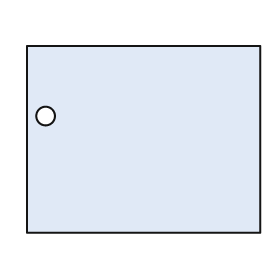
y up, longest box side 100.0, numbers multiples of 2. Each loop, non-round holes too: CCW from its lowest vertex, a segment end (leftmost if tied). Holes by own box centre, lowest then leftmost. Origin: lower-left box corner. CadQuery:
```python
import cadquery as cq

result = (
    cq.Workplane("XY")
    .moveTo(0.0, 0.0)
    .lineTo(100.0, 0.0)
    .lineTo(100.0, 80.0)
    .lineTo(0.0, 80.0)
    .close()
    .moveTo(8.0, 50.0)
    .circle(4.0)
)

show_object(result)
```